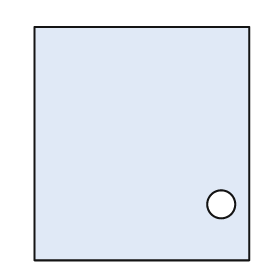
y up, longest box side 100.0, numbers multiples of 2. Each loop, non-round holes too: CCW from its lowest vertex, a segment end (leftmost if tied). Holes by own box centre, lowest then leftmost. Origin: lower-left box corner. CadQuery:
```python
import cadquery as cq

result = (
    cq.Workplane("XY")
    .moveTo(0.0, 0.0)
    .lineTo(92.0, 0.0)
    .lineTo(92.0, 100.0)
    .lineTo(0.0, 100.0)
    .close()
    .moveTo(80.0, 24.0)
    .circle(6.0)
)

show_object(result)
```